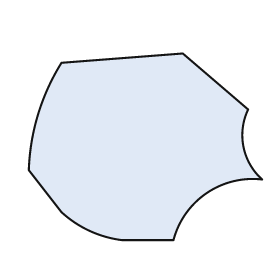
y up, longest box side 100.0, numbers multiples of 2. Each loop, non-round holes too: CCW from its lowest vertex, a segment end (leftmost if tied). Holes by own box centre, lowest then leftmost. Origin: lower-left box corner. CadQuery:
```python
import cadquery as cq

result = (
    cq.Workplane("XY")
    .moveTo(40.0, 0.0)
    .lineTo(62.0, 0.0)
    .threePointArc((76.0, 20.0), (100.0, 26.0))
    .threePointArc((92.0, 40.0), (94.0, 56.0))
    .lineTo(66.0, 80.0)
    .lineTo(14.0, 76.0)
    .threePointArc((4.0, 54.0), (0.0, 30.0))
    .lineTo(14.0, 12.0)
    .threePointArc((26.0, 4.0), (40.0, 0.0))
    .close()
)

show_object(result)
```